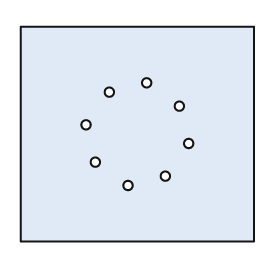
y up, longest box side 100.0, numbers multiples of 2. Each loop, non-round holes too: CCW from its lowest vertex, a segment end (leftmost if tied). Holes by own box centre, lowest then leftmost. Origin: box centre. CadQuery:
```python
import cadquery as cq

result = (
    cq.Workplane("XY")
    .moveTo(-50.0, -46.0)
    .lineTo(50.0, -46.0)
    .lineTo(50.0, 46.0)
    .lineTo(-50.0, 46.0)
    .close()
    .moveTo(-4.0, -22.0)
    .circle(2.0)
    .moveTo(12.0, -18.0)
    .circle(2.0)
    .moveTo(-18.0, -12.0)
    .circle(2.0)
    .moveTo(22.0, -4.0)
    .circle(2.0)
    .moveTo(-22.0, 4.0)
    .circle(2.0)
    .moveTo(18.0, 12.0)
    .circle(2.0)
    .moveTo(-12.0, 18.0)
    .circle(2.0)
    .moveTo(4.0, 22.0)
    .circle(2.0)
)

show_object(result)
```